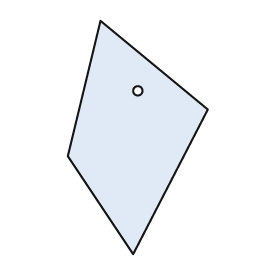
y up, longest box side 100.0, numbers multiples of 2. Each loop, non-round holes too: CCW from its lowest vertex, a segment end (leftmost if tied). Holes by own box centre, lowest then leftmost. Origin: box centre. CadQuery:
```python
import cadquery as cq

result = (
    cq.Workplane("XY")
    .moveTo(-2.0, -50.0)
    .lineTo(30.0, 12.0)
    .lineTo(-16.0, 50.0)
    .lineTo(-30.0, -8.0)
    .close()
    .moveTo(0.0, 20.0)
    .circle(2.0)
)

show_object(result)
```